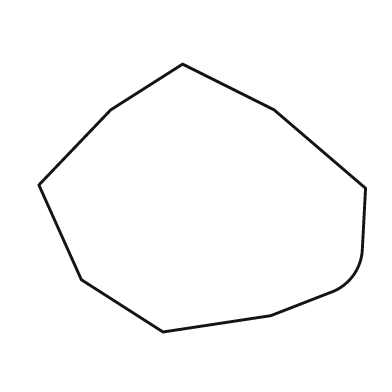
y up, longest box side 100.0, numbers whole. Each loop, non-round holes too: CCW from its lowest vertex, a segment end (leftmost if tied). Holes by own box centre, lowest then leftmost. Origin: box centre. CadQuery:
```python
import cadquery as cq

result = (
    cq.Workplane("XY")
    .moveTo(-12.0, -41.0)
    .lineTo(21.0, -36.0)
    .lineTo(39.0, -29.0)
    .threePointArc((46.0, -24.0), (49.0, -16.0))
    .lineTo(50.0, 3.0)
    .lineTo(22.0, 27.0)
    .lineTo(-6.0, 41.0)
    .lineTo(-28.0, 27.0)
    .lineTo(-50.0, 4.0)
    .lineTo(-37.0, -25.0)
    .close()
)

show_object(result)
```